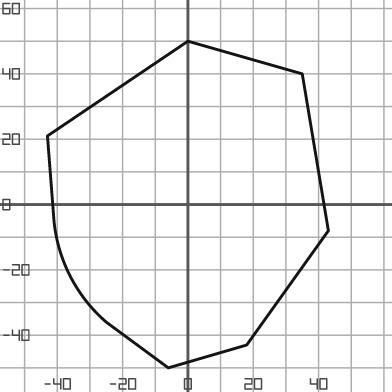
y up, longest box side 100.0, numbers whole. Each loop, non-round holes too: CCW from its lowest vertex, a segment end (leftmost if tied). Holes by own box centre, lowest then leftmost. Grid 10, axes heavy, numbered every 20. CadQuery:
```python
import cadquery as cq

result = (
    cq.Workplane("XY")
    .moveTo(-6.0, -50.0)
    .lineTo(18.0, -43.0)
    .lineTo(43.0, -8.0)
    .lineTo(35.0, 40.0)
    .lineTo(0.0, 50.0)
    .lineTo(-43.0, 21.0)
    .lineTo(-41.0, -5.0)
    .threePointArc((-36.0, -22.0), (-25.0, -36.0))
    .close()
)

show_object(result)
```